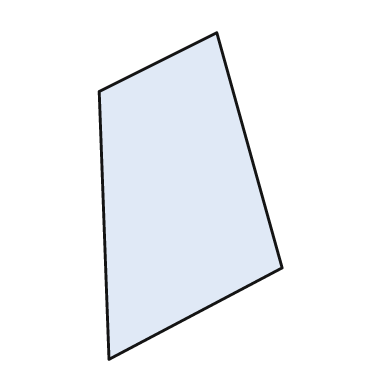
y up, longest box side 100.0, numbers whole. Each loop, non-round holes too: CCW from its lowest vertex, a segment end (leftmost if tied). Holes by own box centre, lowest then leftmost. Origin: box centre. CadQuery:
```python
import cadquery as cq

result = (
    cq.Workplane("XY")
    .moveTo(-25.0, -50.0)
    .lineTo(28.0, -22.0)
    .lineTo(8.0, 50.0)
    .lineTo(-28.0, 32.0)
    .close()
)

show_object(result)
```